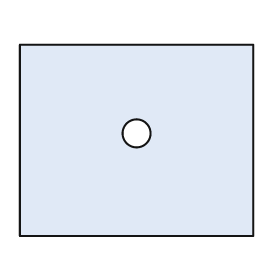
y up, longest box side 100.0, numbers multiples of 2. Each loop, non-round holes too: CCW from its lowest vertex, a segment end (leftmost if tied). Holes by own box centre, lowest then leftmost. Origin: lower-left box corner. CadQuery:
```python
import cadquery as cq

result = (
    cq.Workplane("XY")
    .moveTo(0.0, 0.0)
    .lineTo(100.0, 0.0)
    .lineTo(100.0, 82.0)
    .lineTo(0.0, 82.0)
    .close()
    .moveTo(50.0, 44.0)
    .circle(6.0)
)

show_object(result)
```